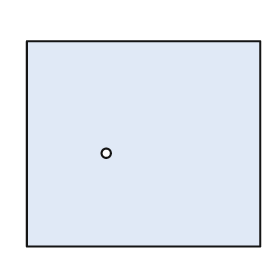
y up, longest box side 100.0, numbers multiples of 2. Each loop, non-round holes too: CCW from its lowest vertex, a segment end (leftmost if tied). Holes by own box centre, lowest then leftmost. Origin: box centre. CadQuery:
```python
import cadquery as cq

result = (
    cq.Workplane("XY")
    .moveTo(-50.0, -44.0)
    .lineTo(50.0, -44.0)
    .lineTo(50.0, 44.0)
    .lineTo(-50.0, 44.0)
    .close()
    .moveTo(-16.0, -4.0)
    .circle(2.0)
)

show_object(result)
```